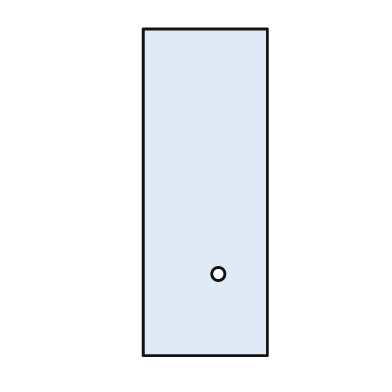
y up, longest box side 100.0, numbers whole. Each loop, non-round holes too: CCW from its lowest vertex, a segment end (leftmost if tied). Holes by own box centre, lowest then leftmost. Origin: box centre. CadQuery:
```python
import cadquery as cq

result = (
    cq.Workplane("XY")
    .moveTo(-19.0, -50.0)
    .lineTo(19.0, -50.0)
    .lineTo(19.0, 50.0)
    .lineTo(-19.0, 50.0)
    .close()
    .moveTo(4.0, -25.0)
    .circle(2.0)
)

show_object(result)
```